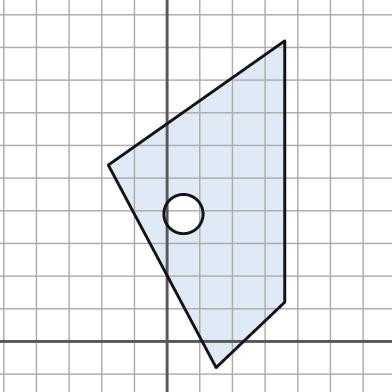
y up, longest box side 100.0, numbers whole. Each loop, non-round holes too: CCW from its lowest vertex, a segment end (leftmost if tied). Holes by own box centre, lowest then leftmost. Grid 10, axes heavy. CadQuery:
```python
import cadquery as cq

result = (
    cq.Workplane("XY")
    .moveTo(15.0, -8.0)
    .lineTo(36.0, 12.0)
    .lineTo(36.0, 92.0)
    .lineTo(-18.0, 54.0)
    .close()
    .moveTo(5.0, 39.0)
    .circle(6.0)
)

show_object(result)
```